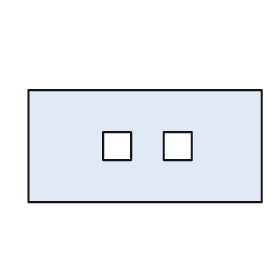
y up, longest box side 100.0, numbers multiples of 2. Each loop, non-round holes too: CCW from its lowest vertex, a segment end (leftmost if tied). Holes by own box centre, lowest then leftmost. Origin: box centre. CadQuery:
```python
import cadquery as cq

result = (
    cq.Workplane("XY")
    .moveTo(-50.0, -24.0)
    .lineTo(50.0, -24.0)
    .lineTo(50.0, 24.0)
    .lineTo(-50.0, 24.0)
    .close()
    .moveTo(-18.0, -6.0)
    .lineTo(-6.0, -6.0)
    .lineTo(-6.0, 6.0)
    .lineTo(-18.0, 6.0)
    .close()
    .moveTo(8.0, -6.0)
    .lineTo(20.0, -6.0)
    .lineTo(20.0, 6.0)
    .lineTo(8.0, 6.0)
    .close()
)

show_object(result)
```